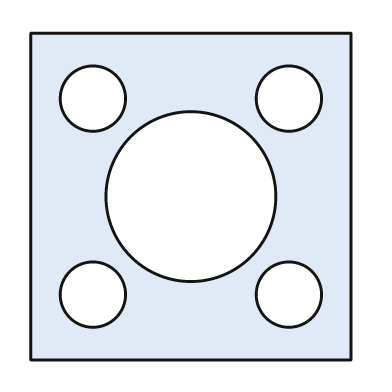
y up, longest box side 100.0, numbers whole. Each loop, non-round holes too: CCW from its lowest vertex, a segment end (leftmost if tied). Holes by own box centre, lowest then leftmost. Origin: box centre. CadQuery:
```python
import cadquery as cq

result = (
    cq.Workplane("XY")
    .moveTo(-49.0, -50.0)
    .lineTo(49.0, -50.0)
    .lineTo(49.0, 50.0)
    .lineTo(-49.0, 50.0)
    .close()
    .moveTo(-30.0, -30.0)
    .circle(10.0)
    .moveTo(30.0, -30.0)
    .circle(10.0)
    .moveTo(0.0, 0.0)
    .circle(26.0)
    .moveTo(-30.0, 30.0)
    .circle(10.0)
    .moveTo(30.0, 30.0)
    .circle(10.0)
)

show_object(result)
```